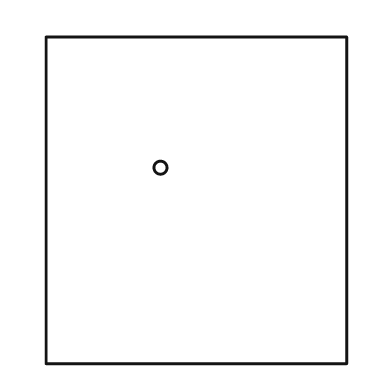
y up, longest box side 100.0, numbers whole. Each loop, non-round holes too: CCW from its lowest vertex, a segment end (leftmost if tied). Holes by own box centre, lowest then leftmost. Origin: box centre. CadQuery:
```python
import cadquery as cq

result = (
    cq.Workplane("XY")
    .moveTo(-46.0, -50.0)
    .lineTo(46.0, -50.0)
    .lineTo(46.0, 50.0)
    .lineTo(-46.0, 50.0)
    .close()
    .moveTo(-11.0, 10.0)
    .circle(2.0)
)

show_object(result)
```